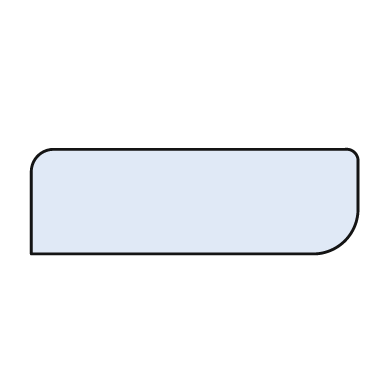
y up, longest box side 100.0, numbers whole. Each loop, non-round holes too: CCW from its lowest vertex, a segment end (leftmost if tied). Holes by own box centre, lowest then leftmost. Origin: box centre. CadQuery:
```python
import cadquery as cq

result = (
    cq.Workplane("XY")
    .moveTo(-50.0, -16.0)
    .lineTo(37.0, -16.0)
    .threePointArc((46.0, -12.0), (50.0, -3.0))
    .lineTo(50.0, 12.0)
    .threePointArc((49.0, 15.0), (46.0, 16.0))
    .lineTo(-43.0, 16.0)
    .threePointArc((-48.0, 14.0), (-50.0, 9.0))
    .close()
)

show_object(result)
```